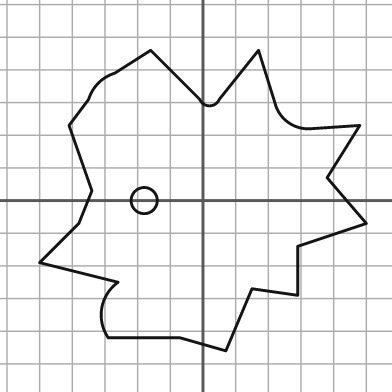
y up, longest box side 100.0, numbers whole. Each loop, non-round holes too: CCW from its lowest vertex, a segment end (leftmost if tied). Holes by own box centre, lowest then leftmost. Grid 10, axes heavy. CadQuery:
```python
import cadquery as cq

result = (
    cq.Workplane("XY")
    .moveTo(7.0, -46.0)
    .lineTo(15.0, -27.0)
    .lineTo(29.0, -29.0)
    .lineTo(29.0, -14.0)
    .lineTo(50.0, -7.0)
    .lineTo(38.0, 7.0)
    .lineTo(48.0, 23.0)
    .lineTo(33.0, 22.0)
    .threePointArc((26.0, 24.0), (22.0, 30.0))
    .lineTo(17.0, 46.0)
    .lineTo(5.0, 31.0)
    .threePointArc((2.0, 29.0), (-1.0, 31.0))
    .lineTo(-16.0, 46.0)
    .lineTo(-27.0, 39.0)
    .threePointArc((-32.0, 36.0), (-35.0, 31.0))
    .lineTo(-41.0, 23.0)
    .lineTo(-34.0, 3.0)
    .lineTo(-38.0, -7.0)
    .lineTo(-50.0, -19.0)
    .lineTo(-26.0, -25.0)
    .threePointArc((-31.0, -33.0), (-29.0, -42.0))
    .lineTo(-7.0, -42.0)
    .close()
    .moveTo(-18.0, 0.0)
    .circle(4.0)
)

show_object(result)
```